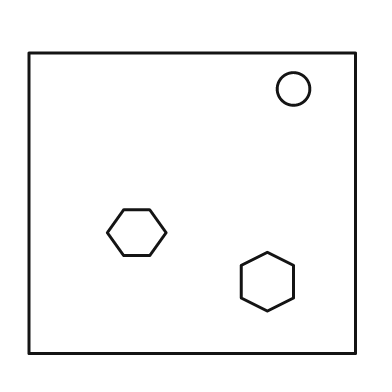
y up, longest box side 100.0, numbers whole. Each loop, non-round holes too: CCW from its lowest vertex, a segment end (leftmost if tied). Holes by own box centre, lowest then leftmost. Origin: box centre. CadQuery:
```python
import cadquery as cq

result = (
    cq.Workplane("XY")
    .moveTo(-50.0, -46.0)
    .lineTo(50.0, -46.0)
    .lineTo(50.0, 46.0)
    .lineTo(-50.0, 46.0)
    .close()
    .moveTo(23.0, -33.0)
    .lineTo(31.0, -29.0)
    .lineTo(31.0, -19.0)
    .lineTo(23.0, -15.0)
    .lineTo(15.0, -19.0)
    .lineTo(15.0, -29.0)
    .close()
    .moveTo(-21.0, -16.0)
    .lineTo(-13.0, -16.0)
    .lineTo(-8.0, -9.0)
    .lineTo(-13.0, -2.0)
    .lineTo(-21.0, -2.0)
    .lineTo(-26.0, -9.0)
    .close()
    .moveTo(31.0, 35.0)
    .circle(5.0)
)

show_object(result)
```